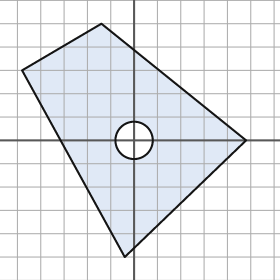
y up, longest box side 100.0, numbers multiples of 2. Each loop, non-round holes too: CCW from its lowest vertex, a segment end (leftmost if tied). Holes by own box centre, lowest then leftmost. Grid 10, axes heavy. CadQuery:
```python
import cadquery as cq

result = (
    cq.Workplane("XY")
    .moveTo(-4.0, -50.0)
    .lineTo(48.0, 0.0)
    .lineTo(-14.0, 50.0)
    .lineTo(-48.0, 30.0)
    .close()
    .moveTo(0.0, 0.0)
    .circle(8.0)
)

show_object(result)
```